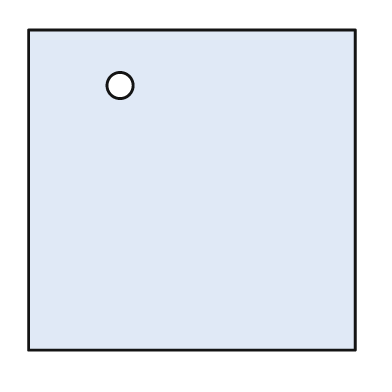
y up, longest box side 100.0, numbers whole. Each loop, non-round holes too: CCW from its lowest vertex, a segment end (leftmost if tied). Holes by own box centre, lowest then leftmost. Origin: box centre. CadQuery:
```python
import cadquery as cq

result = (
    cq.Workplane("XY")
    .moveTo(-50.0, -49.0)
    .lineTo(50.0, -49.0)
    .lineTo(50.0, 49.0)
    .lineTo(-50.0, 49.0)
    .close()
    .moveTo(-22.0, 32.0)
    .circle(4.0)
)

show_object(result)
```